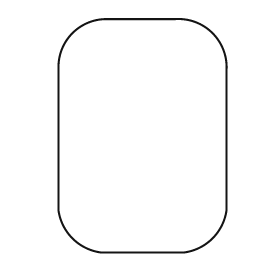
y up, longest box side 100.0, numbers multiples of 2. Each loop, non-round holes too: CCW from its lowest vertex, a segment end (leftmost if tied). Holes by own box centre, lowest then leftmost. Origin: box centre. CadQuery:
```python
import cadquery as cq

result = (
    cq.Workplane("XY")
    .moveTo(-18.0, -50.0)
    .lineTo(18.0, -50.0)
    .threePointArc((30.0, -44.0), (36.0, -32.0))
    .lineTo(36.0, 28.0)
    .threePointArc((30.0, 44.0), (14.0, 50.0))
    .lineTo(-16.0, 50.0)
    .threePointArc((-30.0, 44.0), (-36.0, 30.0))
    .lineTo(-36.0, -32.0)
    .threePointArc((-30.0, -44.0), (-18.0, -50.0))
    .close()
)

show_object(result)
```